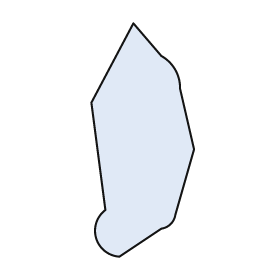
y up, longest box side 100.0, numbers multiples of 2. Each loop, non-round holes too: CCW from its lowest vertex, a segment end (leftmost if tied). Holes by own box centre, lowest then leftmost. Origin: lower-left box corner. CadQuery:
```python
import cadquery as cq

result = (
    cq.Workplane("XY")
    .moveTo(12.0, 0.0)
    .lineTo(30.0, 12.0)
    .threePointArc((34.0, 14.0), (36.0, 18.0))
    .lineTo(44.0, 46.0)
    .lineTo(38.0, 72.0)
    .threePointArc((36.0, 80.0), (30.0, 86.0))
    .lineTo(18.0, 100.0)
    .lineTo(0.0, 66.0)
    .lineTo(6.0, 20.0)
    .threePointArc((2.0, 8.0), (12.0, 0.0))
    .close()
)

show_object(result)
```